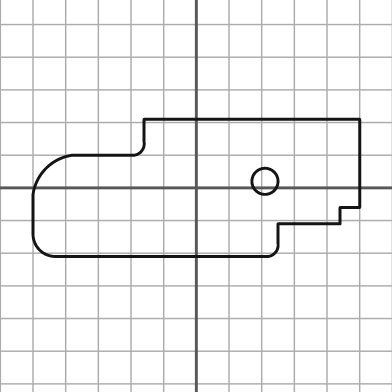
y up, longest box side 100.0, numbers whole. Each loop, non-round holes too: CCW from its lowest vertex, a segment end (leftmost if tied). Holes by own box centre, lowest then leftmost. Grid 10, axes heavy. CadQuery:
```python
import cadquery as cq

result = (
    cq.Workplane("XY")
    .moveTo(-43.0, -21.0)
    .lineTo(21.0, -21.0)
    .threePointArc((24.0, -20.0), (25.0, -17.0))
    .lineTo(25.0, -11.0)
    .lineTo(44.0, -11.0)
    .lineTo(44.0, -6.0)
    .lineTo(50.0, -6.0)
    .lineTo(50.0, 21.0)
    .lineTo(-16.0, 21.0)
    .lineTo(-16.0, 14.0)
    .threePointArc((-17.0, 11.0), (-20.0, 10.0))
    .lineTo(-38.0, 10.0)
    .threePointArc((-46.0, 6.0), (-50.0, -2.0))
    .lineTo(-50.0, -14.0)
    .threePointArc((-48.0, -19.0), (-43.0, -21.0))
    .close()
    .moveTo(21.0, 2.0)
    .circle(4.0)
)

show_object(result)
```